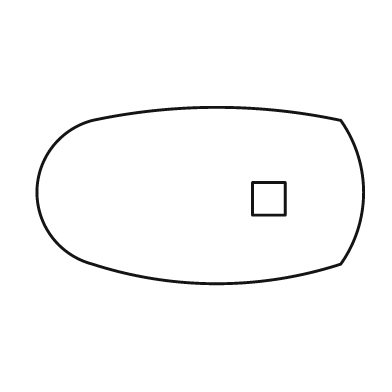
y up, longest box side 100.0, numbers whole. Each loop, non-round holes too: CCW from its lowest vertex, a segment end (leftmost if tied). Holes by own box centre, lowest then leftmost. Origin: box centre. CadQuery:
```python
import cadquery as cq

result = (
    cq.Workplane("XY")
    .moveTo(-33.0, -21.0)
    .threePointArc((5.0, -27.0), (43.0, -21.0))
    .threePointArc((50.0, 1.0), (43.0, 23.0))
    .threePointArc((5.0, 27.0), (-33.0, 23.0))
    .threePointArc((-50.0, 1.0), (-33.0, -21.0))
    .close()
    .moveTo(16.0, -6.0)
    .lineTo(26.0, -6.0)
    .lineTo(26.0, 4.0)
    .lineTo(16.0, 4.0)
    .close()
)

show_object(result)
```